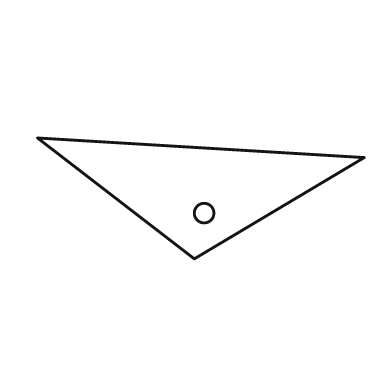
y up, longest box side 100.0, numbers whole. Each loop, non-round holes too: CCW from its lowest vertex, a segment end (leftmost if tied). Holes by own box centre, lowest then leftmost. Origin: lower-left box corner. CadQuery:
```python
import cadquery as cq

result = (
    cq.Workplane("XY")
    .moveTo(48.0, 0.0)
    .lineTo(100.0, 31.0)
    .lineTo(0.0, 37.0)
    .close()
    .moveTo(51.0, 14.0)
    .circle(3.0)
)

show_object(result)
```